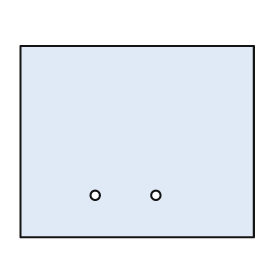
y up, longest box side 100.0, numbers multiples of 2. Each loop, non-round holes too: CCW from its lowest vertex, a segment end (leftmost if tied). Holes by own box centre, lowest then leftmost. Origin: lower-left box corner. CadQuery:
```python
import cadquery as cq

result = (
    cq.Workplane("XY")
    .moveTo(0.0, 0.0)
    .lineTo(100.0, 0.0)
    .lineTo(100.0, 82.0)
    .lineTo(0.0, 82.0)
    .close()
    .moveTo(32.0, 18.0)
    .circle(2.0)
    .moveTo(58.0, 18.0)
    .circle(2.0)
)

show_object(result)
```